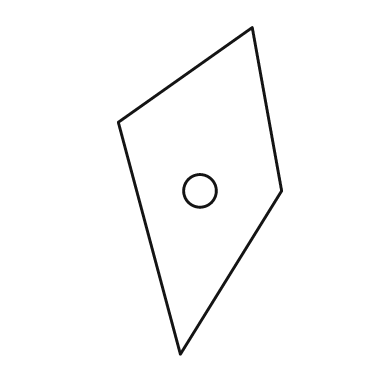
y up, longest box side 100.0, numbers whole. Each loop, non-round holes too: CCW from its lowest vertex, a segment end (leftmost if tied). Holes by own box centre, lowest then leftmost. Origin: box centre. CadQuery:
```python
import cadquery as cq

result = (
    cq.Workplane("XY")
    .moveTo(-6.0, -50.0)
    .lineTo(25.0, 0.0)
    .lineTo(16.0, 50.0)
    .lineTo(-25.0, 21.0)
    .close()
    .moveTo(0.0, 0.0)
    .circle(5.0)
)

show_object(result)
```